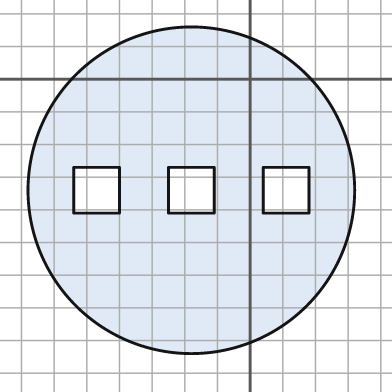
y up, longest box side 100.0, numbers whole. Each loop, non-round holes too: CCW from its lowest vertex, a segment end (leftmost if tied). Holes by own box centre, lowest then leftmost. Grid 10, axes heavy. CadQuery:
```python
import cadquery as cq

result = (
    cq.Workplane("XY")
    .moveTo(-18.0, -34.0)
    .circle(50.0)
    .moveTo(-54.0, -41.0)
    .lineTo(-40.0, -41.0)
    .lineTo(-40.0, -27.0)
    .lineTo(-54.0, -27.0)
    .close()
    .moveTo(-25.0, -41.0)
    .lineTo(-11.0, -41.0)
    .lineTo(-11.0, -27.0)
    .lineTo(-25.0, -27.0)
    .close()
    .moveTo(4.0, -41.0)
    .lineTo(18.0, -41.0)
    .lineTo(18.0, -27.0)
    .lineTo(4.0, -27.0)
    .close()
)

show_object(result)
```